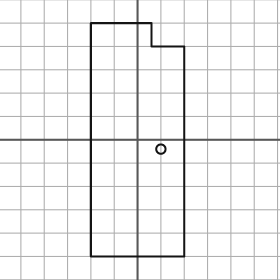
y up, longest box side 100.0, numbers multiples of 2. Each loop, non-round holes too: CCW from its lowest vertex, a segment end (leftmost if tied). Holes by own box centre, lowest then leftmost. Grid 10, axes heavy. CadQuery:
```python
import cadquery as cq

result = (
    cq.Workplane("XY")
    .moveTo(-20.0, -50.0)
    .lineTo(20.0, -50.0)
    .lineTo(20.0, 40.0)
    .lineTo(6.0, 40.0)
    .lineTo(6.0, 50.0)
    .lineTo(-20.0, 50.0)
    .close()
    .moveTo(10.0, -4.0)
    .circle(2.0)
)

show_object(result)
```